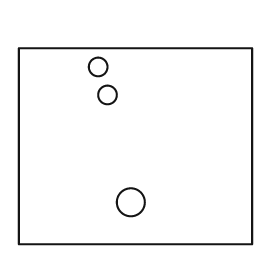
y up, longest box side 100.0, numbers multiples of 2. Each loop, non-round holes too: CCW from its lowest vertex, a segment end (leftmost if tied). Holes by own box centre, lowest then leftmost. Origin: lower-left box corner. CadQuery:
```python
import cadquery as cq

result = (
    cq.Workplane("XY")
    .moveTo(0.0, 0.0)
    .lineTo(100.0, 0.0)
    .lineTo(100.0, 84.0)
    .lineTo(0.0, 84.0)
    .close()
    .moveTo(48.0, 18.0)
    .circle(6.0)
    .moveTo(38.0, 64.0)
    .circle(4.0)
    .moveTo(34.0, 76.0)
    .circle(4.0)
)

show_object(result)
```